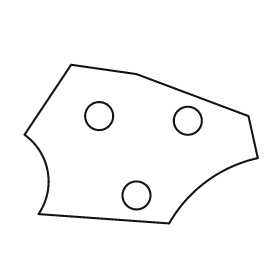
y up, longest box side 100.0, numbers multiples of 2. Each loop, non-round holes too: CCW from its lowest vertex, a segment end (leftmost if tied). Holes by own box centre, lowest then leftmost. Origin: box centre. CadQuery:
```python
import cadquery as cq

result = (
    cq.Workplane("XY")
    .moveTo(12.0, -34.0)
    .threePointArc((28.0, -16.0), (50.0, -6.0))
    .lineTo(46.0, 12.0)
    .lineTo(-2.0, 30.0)
    .lineTo(-30.0, 34.0)
    .lineTo(-50.0, 4.0)
    .threePointArc((-40.0, -12.0), (-44.0, -30.0))
    .close()
    .moveTo(-2.0, -22.0)
    .circle(6.0)
    .moveTo(20.0, 10.0)
    .circle(6.0)
    .moveTo(-18.0, 12.0)
    .circle(6.0)
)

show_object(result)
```